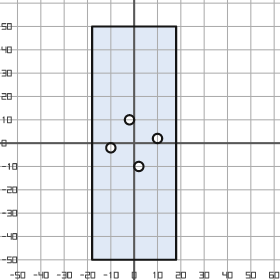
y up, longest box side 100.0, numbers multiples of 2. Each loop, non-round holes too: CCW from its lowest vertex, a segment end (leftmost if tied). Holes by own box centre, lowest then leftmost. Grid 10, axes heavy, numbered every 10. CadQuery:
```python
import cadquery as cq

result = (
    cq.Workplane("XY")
    .moveTo(-18.0, -50.0)
    .lineTo(18.0, -50.0)
    .lineTo(18.0, 50.0)
    .lineTo(-18.0, 50.0)
    .close()
    .moveTo(2.0, -10.0)
    .circle(2.0)
    .moveTo(-10.0, -2.0)
    .circle(2.0)
    .moveTo(10.0, 2.0)
    .circle(2.0)
    .moveTo(-2.0, 10.0)
    .circle(2.0)
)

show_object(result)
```